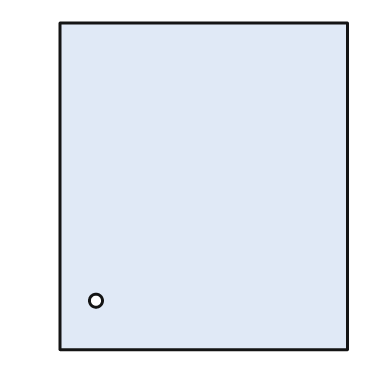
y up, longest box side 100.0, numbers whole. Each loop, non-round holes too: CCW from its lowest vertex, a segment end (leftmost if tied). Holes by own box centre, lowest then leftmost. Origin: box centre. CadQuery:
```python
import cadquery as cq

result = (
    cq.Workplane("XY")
    .moveTo(-44.0, -50.0)
    .lineTo(44.0, -50.0)
    .lineTo(44.0, 50.0)
    .lineTo(-44.0, 50.0)
    .close()
    .moveTo(-33.0, -35.0)
    .circle(2.0)
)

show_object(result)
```